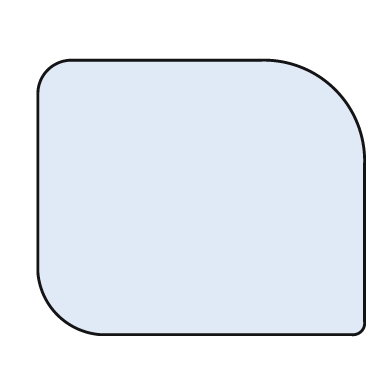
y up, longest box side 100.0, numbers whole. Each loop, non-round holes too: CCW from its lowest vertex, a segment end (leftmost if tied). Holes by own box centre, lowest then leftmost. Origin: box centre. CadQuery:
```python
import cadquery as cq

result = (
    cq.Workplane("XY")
    .moveTo(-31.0, -42.0)
    .lineTo(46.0, -42.0)
    .threePointArc((49.0, -41.0), (50.0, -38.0))
    .lineTo(50.0, 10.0)
    .threePointArc((41.0, 33.0), (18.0, 42.0))
    .lineTo(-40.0, 42.0)
    .threePointArc((-47.0, 39.0), (-50.0, 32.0))
    .lineTo(-50.0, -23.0)
    .threePointArc((-44.0, -36.0), (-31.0, -42.0))
    .close()
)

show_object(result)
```